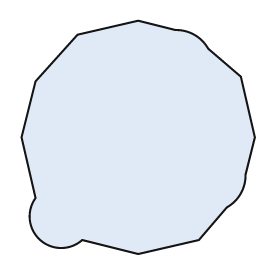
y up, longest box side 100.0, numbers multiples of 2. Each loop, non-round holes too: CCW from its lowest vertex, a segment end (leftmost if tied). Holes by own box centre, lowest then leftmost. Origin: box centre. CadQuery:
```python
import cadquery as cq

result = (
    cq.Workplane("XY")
    .moveTo(0.0, -50.0)
    .lineTo(26.0, -44.0)
    .lineTo(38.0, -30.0)
    .threePointArc((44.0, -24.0), (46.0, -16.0))
    .lineTo(50.0, 0.0)
    .lineTo(44.0, 26.0)
    .lineTo(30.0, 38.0)
    .threePointArc((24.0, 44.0), (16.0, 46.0))
    .lineTo(0.0, 50.0)
    .lineTo(-26.0, 44.0)
    .lineTo(-44.0, 24.0)
    .lineTo(-50.0, 0.0)
    .lineTo(-44.0, -26.0)
    .threePointArc((-42.0, -44.0), (-24.0, -44.0))
    .close()
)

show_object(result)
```